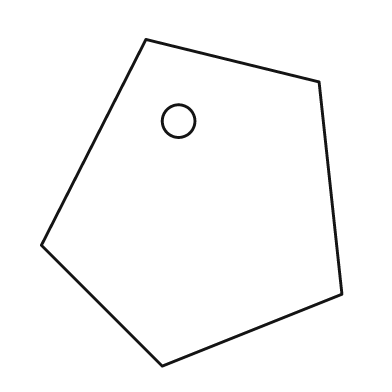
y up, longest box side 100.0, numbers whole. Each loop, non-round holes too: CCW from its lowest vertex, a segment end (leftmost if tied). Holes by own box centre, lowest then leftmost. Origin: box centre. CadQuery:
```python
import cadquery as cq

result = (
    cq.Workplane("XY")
    .moveTo(-9.0, -50.0)
    .lineTo(46.0, -28.0)
    .lineTo(39.0, 37.0)
    .lineTo(-14.0, 50.0)
    .lineTo(-46.0, -13.0)
    .close()
    .moveTo(-4.0, 25.0)
    .circle(5.0)
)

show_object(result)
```